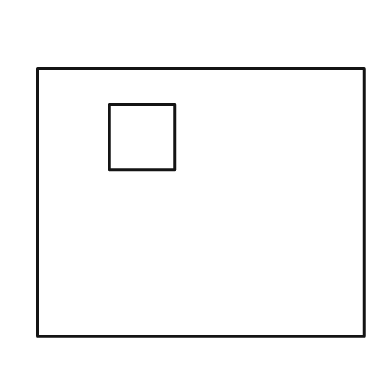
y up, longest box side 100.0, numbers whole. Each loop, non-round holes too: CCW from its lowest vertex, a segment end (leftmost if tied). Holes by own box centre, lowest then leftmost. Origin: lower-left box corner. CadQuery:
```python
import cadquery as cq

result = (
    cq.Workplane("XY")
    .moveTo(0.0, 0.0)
    .lineTo(100.0, 0.0)
    .lineTo(100.0, 82.0)
    .lineTo(0.0, 82.0)
    .close()
    .moveTo(22.0, 51.0)
    .lineTo(42.0, 51.0)
    .lineTo(42.0, 71.0)
    .lineTo(22.0, 71.0)
    .close()
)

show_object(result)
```